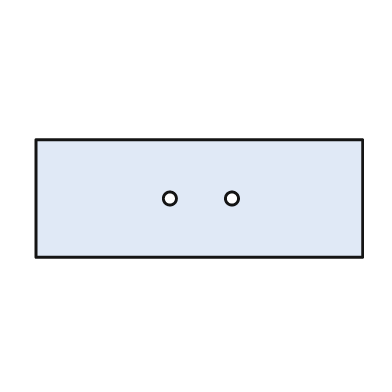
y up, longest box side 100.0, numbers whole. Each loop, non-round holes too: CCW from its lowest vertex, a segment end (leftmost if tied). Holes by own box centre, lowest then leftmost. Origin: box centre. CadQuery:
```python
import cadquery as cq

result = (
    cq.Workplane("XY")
    .moveTo(-50.0, -18.0)
    .lineTo(50.0, -18.0)
    .lineTo(50.0, 18.0)
    .lineTo(-50.0, 18.0)
    .close()
    .moveTo(-9.0, 0.0)
    .circle(2.0)
    .moveTo(10.0, 0.0)
    .circle(2.0)
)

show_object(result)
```